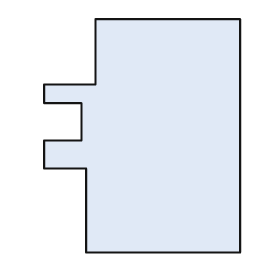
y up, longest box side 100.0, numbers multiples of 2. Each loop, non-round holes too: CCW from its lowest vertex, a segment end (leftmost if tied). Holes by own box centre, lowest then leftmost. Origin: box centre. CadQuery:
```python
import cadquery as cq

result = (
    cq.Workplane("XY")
    .moveTo(-24.0, -50.0)
    .lineTo(42.0, -50.0)
    .lineTo(42.0, 50.0)
    .lineTo(-20.0, 50.0)
    .lineTo(-20.0, 22.0)
    .lineTo(-42.0, 22.0)
    .lineTo(-42.0, 14.0)
    .lineTo(-26.0, 14.0)
    .lineTo(-26.0, -2.0)
    .lineTo(-42.0, -2.0)
    .lineTo(-42.0, -14.0)
    .lineTo(-24.0, -14.0)
    .close()
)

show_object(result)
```